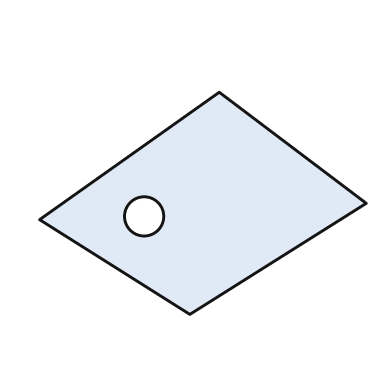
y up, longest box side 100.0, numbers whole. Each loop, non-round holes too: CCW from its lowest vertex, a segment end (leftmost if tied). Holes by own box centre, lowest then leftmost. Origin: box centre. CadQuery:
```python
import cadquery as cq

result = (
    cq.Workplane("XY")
    .moveTo(-4.0, -34.0)
    .lineTo(50.0, 0.0)
    .lineTo(5.0, 34.0)
    .lineTo(-50.0, -5.0)
    .close()
    .moveTo(-18.0, -4.0)
    .circle(6.0)
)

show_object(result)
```